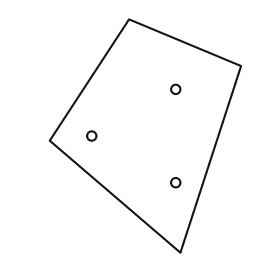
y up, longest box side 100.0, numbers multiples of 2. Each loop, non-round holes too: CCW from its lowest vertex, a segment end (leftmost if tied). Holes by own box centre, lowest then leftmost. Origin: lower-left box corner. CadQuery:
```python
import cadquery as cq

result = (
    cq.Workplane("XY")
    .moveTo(56.0, 0.0)
    .lineTo(82.0, 80.0)
    .lineTo(34.0, 100.0)
    .lineTo(0.0, 48.0)
    .close()
    .moveTo(54.0, 30.0)
    .circle(2.0)
    .moveTo(18.0, 50.0)
    .circle(2.0)
    .moveTo(54.0, 70.0)
    .circle(2.0)
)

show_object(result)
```